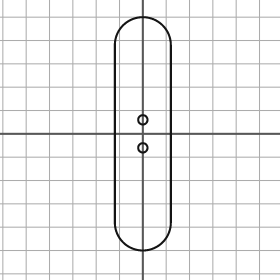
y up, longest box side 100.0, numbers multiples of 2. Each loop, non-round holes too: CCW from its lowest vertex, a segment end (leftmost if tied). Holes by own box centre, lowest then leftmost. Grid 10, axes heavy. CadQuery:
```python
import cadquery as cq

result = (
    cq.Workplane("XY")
    .moveTo(-12.0, -38.0)
    .threePointArc((0.0, -50.0), (12.0, -38.0))
    .lineTo(12.0, 38.0)
    .threePointArc((0.0, 50.0), (-12.0, 38.0))
    .close()
    .moveTo(0.0, -6.0)
    .circle(2.0)
    .moveTo(0.0, 6.0)
    .circle(2.0)
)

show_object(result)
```